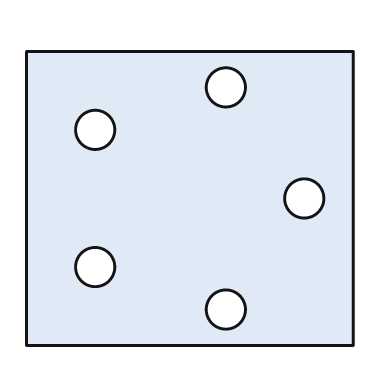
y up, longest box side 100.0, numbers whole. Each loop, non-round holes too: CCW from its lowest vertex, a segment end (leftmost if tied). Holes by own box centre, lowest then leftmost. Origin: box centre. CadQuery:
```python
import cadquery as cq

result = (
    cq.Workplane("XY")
    .moveTo(-50.0, -45.0)
    .lineTo(50.0, -45.0)
    .lineTo(50.0, 45.0)
    .lineTo(-50.0, 45.0)
    .close()
    .moveTo(11.0, -34.0)
    .circle(6.0)
    .moveTo(-29.0, -21.0)
    .circle(6.0)
    .moveTo(35.0, 0.0)
    .circle(6.0)
    .moveTo(-29.0, 21.0)
    .circle(6.0)
    .moveTo(11.0, 34.0)
    .circle(6.0)
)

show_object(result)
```